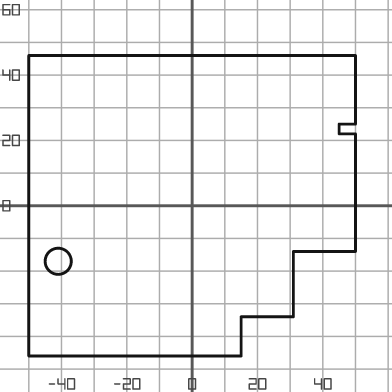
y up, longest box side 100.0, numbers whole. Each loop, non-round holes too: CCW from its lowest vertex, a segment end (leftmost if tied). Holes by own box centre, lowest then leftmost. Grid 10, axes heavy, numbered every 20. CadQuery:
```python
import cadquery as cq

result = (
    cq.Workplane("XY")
    .moveTo(-50.0, -46.0)
    .lineTo(15.0, -46.0)
    .lineTo(15.0, -34.0)
    .lineTo(31.0, -34.0)
    .lineTo(31.0, -14.0)
    .lineTo(50.0, -14.0)
    .lineTo(50.0, 22.0)
    .lineTo(45.0, 22.0)
    .lineTo(45.0, 25.0)
    .lineTo(50.0, 25.0)
    .lineTo(50.0, 46.0)
    .lineTo(-50.0, 46.0)
    .close()
    .moveTo(-41.0, -17.0)
    .circle(4.0)
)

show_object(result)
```